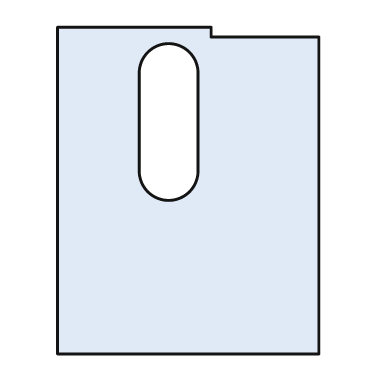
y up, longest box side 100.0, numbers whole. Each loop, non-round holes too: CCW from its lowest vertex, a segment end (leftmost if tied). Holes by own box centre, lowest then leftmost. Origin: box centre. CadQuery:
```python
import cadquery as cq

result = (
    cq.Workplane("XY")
    .moveTo(-40.0, -50.0)
    .lineTo(40.0, -50.0)
    .lineTo(40.0, 47.0)
    .lineTo(7.0, 47.0)
    .lineTo(7.0, 50.0)
    .lineTo(-40.0, 50.0)
    .close()
    .moveTo(-15.0, 6.0)
    .threePointArc((-6.0, -3.0), (3.0, 6.0))
    .lineTo(3.0, 36.0)
    .threePointArc((-6.0, 45.0), (-15.0, 36.0))
    .close()
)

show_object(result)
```